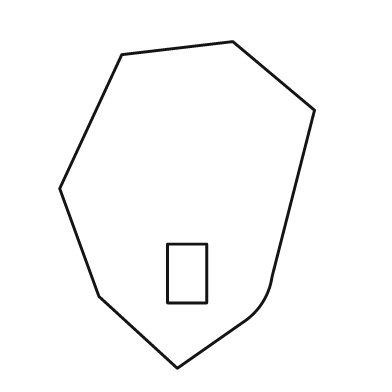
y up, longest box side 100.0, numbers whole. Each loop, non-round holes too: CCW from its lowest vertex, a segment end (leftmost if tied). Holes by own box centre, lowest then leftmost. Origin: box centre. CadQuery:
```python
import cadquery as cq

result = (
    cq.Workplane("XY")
    .moveTo(-3.0, -50.0)
    .lineTo(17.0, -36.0)
    .threePointArc((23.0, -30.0), (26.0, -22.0))
    .lineTo(39.0, 29.0)
    .lineTo(14.0, 50.0)
    .lineTo(-20.0, 46.0)
    .lineTo(-39.0, 5.0)
    .lineTo(-27.0, -28.0)
    .close()
    .moveTo(-6.0, -30.0)
    .lineTo(6.0, -30.0)
    .lineTo(6.0, -12.0)
    .lineTo(-6.0, -12.0)
    .close()
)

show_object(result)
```